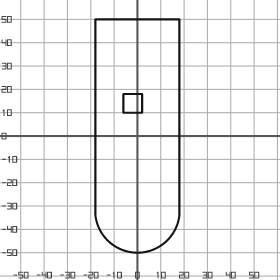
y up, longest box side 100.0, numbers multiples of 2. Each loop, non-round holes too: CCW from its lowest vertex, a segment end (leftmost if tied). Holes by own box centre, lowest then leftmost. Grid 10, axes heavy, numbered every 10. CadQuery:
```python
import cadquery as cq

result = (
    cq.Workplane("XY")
    .moveTo(-18.0, -34.0)
    .threePointArc((0.0, -50.0), (18.0, -34.0))
    .lineTo(18.0, 50.0)
    .lineTo(-18.0, 50.0)
    .close()
    .moveTo(-6.0, 10.0)
    .lineTo(2.0, 10.0)
    .lineTo(2.0, 18.0)
    .lineTo(-6.0, 18.0)
    .close()
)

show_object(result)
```